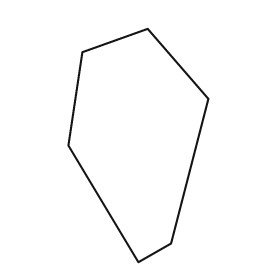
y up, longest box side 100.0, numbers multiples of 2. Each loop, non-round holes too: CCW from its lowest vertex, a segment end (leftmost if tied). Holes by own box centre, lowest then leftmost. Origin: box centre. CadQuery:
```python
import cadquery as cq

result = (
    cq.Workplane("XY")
    .moveTo(0.0, -50.0)
    .lineTo(14.0, -42.0)
    .lineTo(30.0, 20.0)
    .lineTo(4.0, 50.0)
    .lineTo(-24.0, 40.0)
    .lineTo(-30.0, 0.0)
    .close()
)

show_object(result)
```